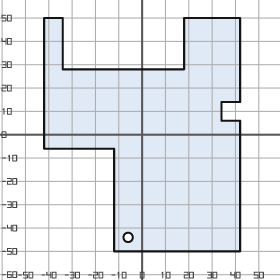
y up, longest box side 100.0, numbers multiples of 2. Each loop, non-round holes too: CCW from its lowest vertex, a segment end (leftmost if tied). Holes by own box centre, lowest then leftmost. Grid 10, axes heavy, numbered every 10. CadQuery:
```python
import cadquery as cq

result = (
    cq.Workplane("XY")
    .moveTo(-12.0, -50.0)
    .lineTo(42.0, -50.0)
    .lineTo(42.0, 6.0)
    .lineTo(34.0, 6.0)
    .lineTo(34.0, 14.0)
    .lineTo(42.0, 14.0)
    .lineTo(42.0, 50.0)
    .lineTo(18.0, 50.0)
    .lineTo(18.0, 28.0)
    .lineTo(-34.0, 28.0)
    .lineTo(-34.0, 50.0)
    .lineTo(-42.0, 50.0)
    .lineTo(-42.0, -6.0)
    .lineTo(-12.0, -6.0)
    .close()
    .moveTo(-6.0, -44.0)
    .circle(2.0)
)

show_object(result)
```